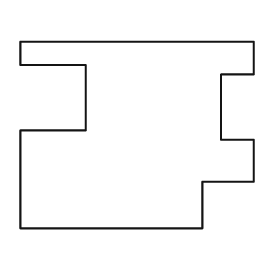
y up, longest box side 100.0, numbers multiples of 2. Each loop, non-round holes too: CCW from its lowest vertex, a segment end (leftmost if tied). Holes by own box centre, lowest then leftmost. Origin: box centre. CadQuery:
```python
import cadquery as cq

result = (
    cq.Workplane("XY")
    .moveTo(-50.0, -40.0)
    .lineTo(28.0, -40.0)
    .lineTo(28.0, -20.0)
    .lineTo(50.0, -20.0)
    .lineTo(50.0, -2.0)
    .lineTo(36.0, -2.0)
    .lineTo(36.0, 26.0)
    .lineTo(50.0, 26.0)
    .lineTo(50.0, 40.0)
    .lineTo(-50.0, 40.0)
    .lineTo(-50.0, 30.0)
    .lineTo(-22.0, 30.0)
    .lineTo(-22.0, 2.0)
    .lineTo(-50.0, 2.0)
    .close()
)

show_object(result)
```